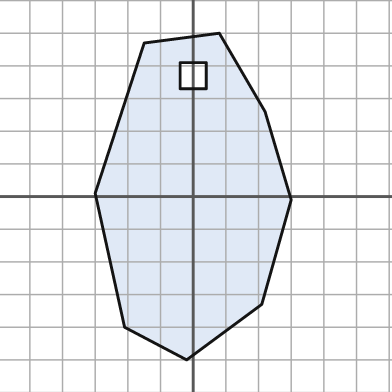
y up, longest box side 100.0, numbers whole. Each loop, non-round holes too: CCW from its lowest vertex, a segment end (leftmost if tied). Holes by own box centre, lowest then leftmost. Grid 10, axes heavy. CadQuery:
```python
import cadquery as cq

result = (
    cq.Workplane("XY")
    .moveTo(-2.0, -50.0)
    .lineTo(21.0, -33.0)
    .lineTo(30.0, -1.0)
    .lineTo(22.0, 26.0)
    .lineTo(8.0, 50.0)
    .lineTo(-15.0, 47.0)
    .lineTo(-30.0, 1.0)
    .lineTo(-21.0, -40.0)
    .close()
    .moveTo(-4.0, 33.0)
    .lineTo(4.0, 33.0)
    .lineTo(4.0, 41.0)
    .lineTo(-4.0, 41.0)
    .close()
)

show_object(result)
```